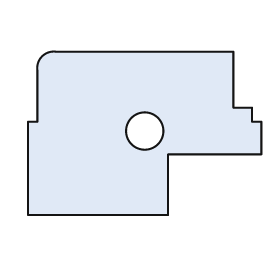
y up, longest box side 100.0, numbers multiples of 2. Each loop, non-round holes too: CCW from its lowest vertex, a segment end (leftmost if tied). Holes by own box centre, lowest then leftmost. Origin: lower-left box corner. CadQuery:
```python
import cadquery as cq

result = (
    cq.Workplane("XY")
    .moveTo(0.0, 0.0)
    .lineTo(60.0, 0.0)
    .lineTo(60.0, 26.0)
    .lineTo(100.0, 26.0)
    .lineTo(100.0, 40.0)
    .lineTo(96.0, 40.0)
    .lineTo(96.0, 46.0)
    .lineTo(88.0, 46.0)
    .lineTo(88.0, 70.0)
    .lineTo(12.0, 70.0)
    .threePointArc((6.0, 68.0), (4.0, 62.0))
    .lineTo(4.0, 40.0)
    .lineTo(0.0, 40.0)
    .close()
    .moveTo(50.0, 36.0)
    .circle(8.0)
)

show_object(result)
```